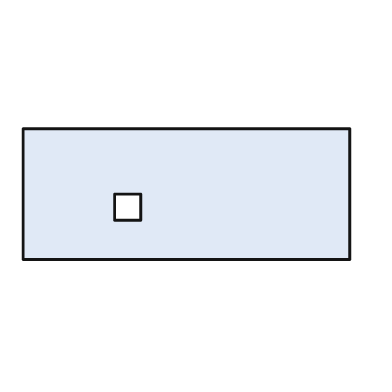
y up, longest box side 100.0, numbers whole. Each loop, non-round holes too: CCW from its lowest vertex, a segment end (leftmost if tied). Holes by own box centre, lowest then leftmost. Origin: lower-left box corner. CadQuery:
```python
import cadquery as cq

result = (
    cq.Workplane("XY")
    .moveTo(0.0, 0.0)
    .lineTo(100.0, 0.0)
    .lineTo(100.0, 40.0)
    .lineTo(0.0, 40.0)
    .close()
    .moveTo(28.0, 12.0)
    .lineTo(36.0, 12.0)
    .lineTo(36.0, 20.0)
    .lineTo(28.0, 20.0)
    .close()
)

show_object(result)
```